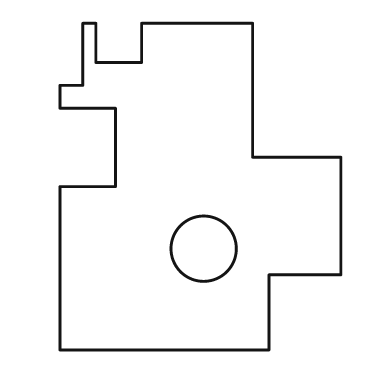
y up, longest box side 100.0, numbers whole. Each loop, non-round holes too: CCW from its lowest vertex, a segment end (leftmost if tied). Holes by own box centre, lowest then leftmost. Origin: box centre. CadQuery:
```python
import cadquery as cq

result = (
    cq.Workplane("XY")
    .moveTo(-43.0, -50.0)
    .lineTo(21.0, -50.0)
    .lineTo(21.0, -27.0)
    .lineTo(43.0, -27.0)
    .lineTo(43.0, 9.0)
    .lineTo(16.0, 9.0)
    .lineTo(16.0, 50.0)
    .lineTo(-18.0, 50.0)
    .lineTo(-18.0, 38.0)
    .lineTo(-32.0, 38.0)
    .lineTo(-32.0, 50.0)
    .lineTo(-36.0, 50.0)
    .lineTo(-36.0, 31.0)
    .lineTo(-43.0, 31.0)
    .lineTo(-43.0, 24.0)
    .lineTo(-26.0, 24.0)
    .lineTo(-26.0, 0.0)
    .lineTo(-43.0, 0.0)
    .close()
    .moveTo(1.0, -19.0)
    .circle(10.0)
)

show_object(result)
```